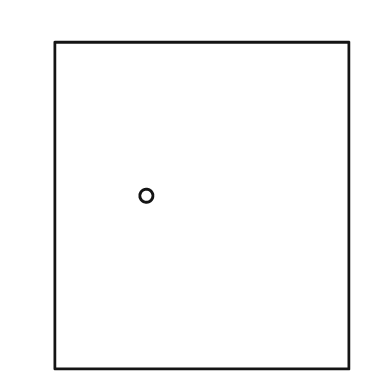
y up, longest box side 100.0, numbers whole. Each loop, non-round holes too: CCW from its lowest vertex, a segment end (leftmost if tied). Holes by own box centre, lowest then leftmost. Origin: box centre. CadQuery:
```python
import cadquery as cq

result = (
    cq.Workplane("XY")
    .moveTo(-45.0, -50.0)
    .lineTo(45.0, -50.0)
    .lineTo(45.0, 50.0)
    .lineTo(-45.0, 50.0)
    .close()
    .moveTo(-17.0, 3.0)
    .circle(2.0)
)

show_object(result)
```